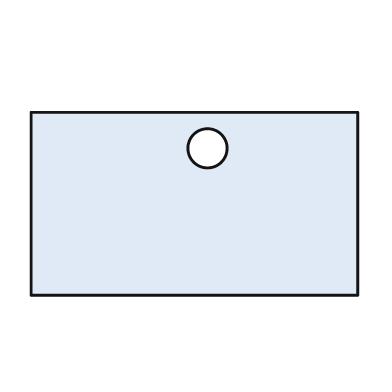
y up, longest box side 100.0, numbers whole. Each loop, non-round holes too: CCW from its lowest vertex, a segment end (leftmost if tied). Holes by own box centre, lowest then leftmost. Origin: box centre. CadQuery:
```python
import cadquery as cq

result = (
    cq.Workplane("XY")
    .moveTo(-50.0, -28.0)
    .lineTo(50.0, -28.0)
    .lineTo(50.0, 28.0)
    .lineTo(-50.0, 28.0)
    .close()
    .moveTo(4.0, 17.0)
    .circle(6.0)
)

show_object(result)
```